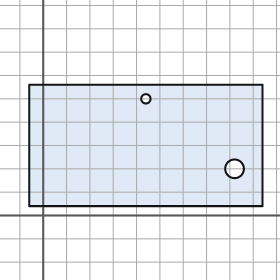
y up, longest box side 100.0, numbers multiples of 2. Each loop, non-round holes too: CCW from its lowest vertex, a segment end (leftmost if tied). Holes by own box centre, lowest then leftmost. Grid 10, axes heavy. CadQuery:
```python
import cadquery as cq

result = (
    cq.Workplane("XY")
    .moveTo(-6.0, 4.0)
    .lineTo(94.0, 4.0)
    .lineTo(94.0, 56.0)
    .lineTo(-6.0, 56.0)
    .close()
    .moveTo(82.0, 20.0)
    .circle(4.0)
    .moveTo(44.0, 50.0)
    .circle(2.0)
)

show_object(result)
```